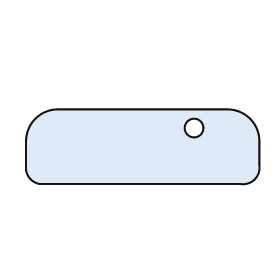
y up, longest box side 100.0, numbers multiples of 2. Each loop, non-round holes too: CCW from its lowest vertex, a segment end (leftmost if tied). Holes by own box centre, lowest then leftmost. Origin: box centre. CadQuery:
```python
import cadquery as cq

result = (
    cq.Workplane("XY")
    .moveTo(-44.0, -16.0)
    .lineTo(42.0, -16.0)
    .threePointArc((48.0, -14.0), (50.0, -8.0))
    .lineTo(50.0, 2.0)
    .threePointArc((46.0, 12.0), (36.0, 16.0))
    .lineTo(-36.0, 16.0)
    .threePointArc((-46.0, 12.0), (-50.0, 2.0))
    .lineTo(-50.0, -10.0)
    .threePointArc((-48.0, -14.0), (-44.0, -16.0))
    .close()
    .moveTo(22.0, 8.0)
    .circle(4.0)
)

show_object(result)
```